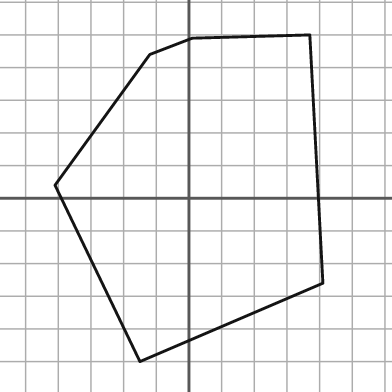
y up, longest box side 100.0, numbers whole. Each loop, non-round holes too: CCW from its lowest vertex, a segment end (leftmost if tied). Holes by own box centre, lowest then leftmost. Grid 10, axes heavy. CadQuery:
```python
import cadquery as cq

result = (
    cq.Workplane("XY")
    .moveTo(-15.0, -50.0)
    .lineTo(41.0, -26.0)
    .lineTo(37.0, 50.0)
    .lineTo(1.0, 49.0)
    .lineTo(-12.0, 44.0)
    .lineTo(-41.0, 4.0)
    .close()
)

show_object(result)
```